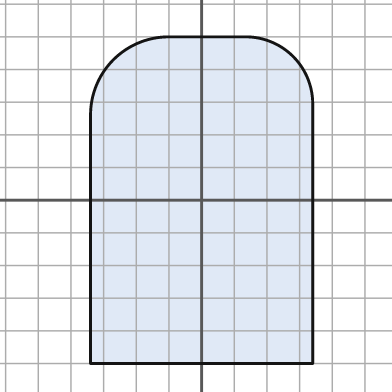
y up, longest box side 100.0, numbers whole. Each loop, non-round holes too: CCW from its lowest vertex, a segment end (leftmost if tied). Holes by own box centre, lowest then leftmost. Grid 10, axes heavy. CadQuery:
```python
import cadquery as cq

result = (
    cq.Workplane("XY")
    .moveTo(-34.0, -50.0)
    .lineTo(34.0, -50.0)
    .lineTo(34.0, 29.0)
    .threePointArc((28.0, 44.0), (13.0, 50.0))
    .lineTo(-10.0, 50.0)
    .threePointArc((-27.0, 43.0), (-34.0, 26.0))
    .close()
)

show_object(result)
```